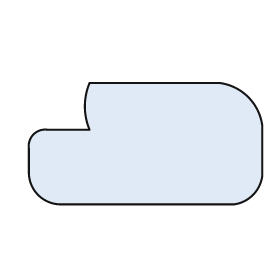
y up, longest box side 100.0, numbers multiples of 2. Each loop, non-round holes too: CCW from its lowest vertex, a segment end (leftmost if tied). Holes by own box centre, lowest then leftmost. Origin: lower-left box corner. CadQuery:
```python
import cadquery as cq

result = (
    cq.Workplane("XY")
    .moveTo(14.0, 0.0)
    .lineTo(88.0, 0.0)
    .threePointArc((96.0, 4.0), (100.0, 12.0))
    .lineTo(100.0, 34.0)
    .threePointArc((94.0, 46.0), (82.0, 52.0))
    .lineTo(26.0, 52.0)
    .threePointArc((24.0, 42.0), (26.0, 32.0))
    .lineTo(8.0, 32.0)
    .threePointArc((2.0, 30.0), (0.0, 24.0))
    .lineTo(0.0, 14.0)
    .threePointArc((4.0, 4.0), (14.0, 0.0))
    .close()
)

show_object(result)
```